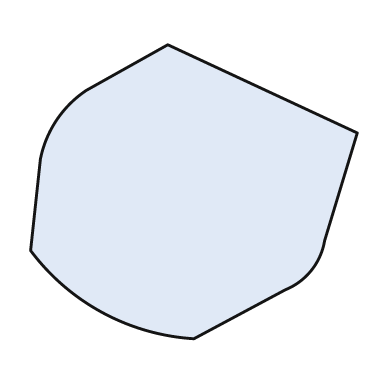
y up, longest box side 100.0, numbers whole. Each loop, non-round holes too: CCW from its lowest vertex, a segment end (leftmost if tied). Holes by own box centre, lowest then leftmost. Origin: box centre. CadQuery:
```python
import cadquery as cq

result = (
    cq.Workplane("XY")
    .moveTo(0.0, -45.0)
    .lineTo(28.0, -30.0)
    .threePointArc((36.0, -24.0), (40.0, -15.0))
    .lineTo(50.0, 18.0)
    .lineTo(-8.0, 45.0)
    .lineTo(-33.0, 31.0)
    .threePointArc((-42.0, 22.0), (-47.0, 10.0))
    .lineTo(-50.0, -18.0)
    .threePointArc((-28.0, -37.0), (0.0, -45.0))
    .close()
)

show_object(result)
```